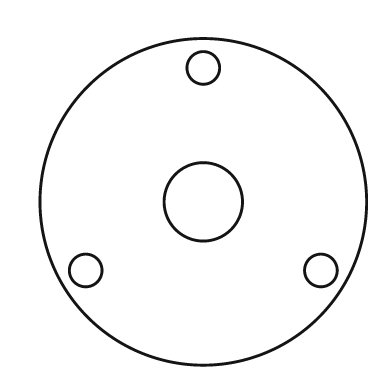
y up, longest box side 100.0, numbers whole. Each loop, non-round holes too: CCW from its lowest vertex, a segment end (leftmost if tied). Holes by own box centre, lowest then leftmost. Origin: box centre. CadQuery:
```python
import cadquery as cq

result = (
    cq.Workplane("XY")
    .moveTo(0.0, 0.0)
    .circle(50.0)
    .moveTo(-36.0, -21.0)
    .circle(5.0)
    .moveTo(36.0, -21.0)
    .circle(5.0)
    .moveTo(0.0, 0.0)
    .circle(12.0)
    .moveTo(0.0, 41.0)
    .circle(5.0)
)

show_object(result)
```